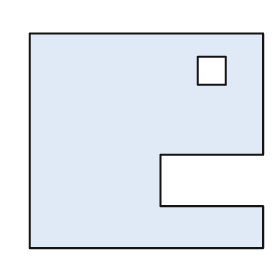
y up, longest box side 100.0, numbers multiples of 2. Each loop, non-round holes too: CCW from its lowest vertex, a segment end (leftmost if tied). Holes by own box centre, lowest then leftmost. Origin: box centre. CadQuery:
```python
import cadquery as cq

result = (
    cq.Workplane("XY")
    .moveTo(-50.0, -46.0)
    .lineTo(50.0, -46.0)
    .lineTo(50.0, -28.0)
    .lineTo(6.0, -28.0)
    .lineTo(6.0, -6.0)
    .lineTo(50.0, -6.0)
    .lineTo(50.0, 46.0)
    .lineTo(-50.0, 46.0)
    .close()
    .moveTo(22.0, 24.0)
    .lineTo(34.0, 24.0)
    .lineTo(34.0, 36.0)
    .lineTo(22.0, 36.0)
    .close()
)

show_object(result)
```